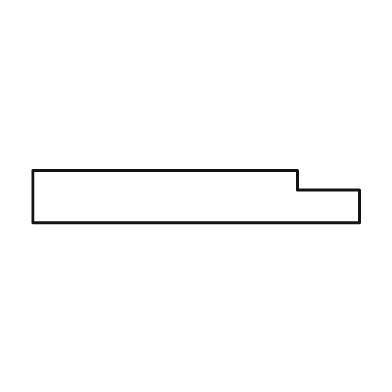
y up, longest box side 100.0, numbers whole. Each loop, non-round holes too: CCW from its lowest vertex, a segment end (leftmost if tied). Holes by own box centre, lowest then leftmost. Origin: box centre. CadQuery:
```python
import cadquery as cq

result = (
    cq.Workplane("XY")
    .moveTo(-50.0, -8.0)
    .lineTo(50.0, -8.0)
    .lineTo(50.0, 2.0)
    .lineTo(31.0, 2.0)
    .lineTo(31.0, 8.0)
    .lineTo(-50.0, 8.0)
    .close()
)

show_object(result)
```